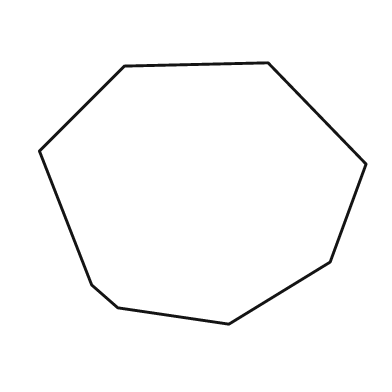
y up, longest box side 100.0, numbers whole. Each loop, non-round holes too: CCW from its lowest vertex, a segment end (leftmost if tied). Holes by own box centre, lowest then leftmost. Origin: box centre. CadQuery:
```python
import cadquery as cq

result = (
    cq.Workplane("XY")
    .moveTo(8.0, -40.0)
    .lineTo(39.0, -21.0)
    .lineTo(50.0, 9.0)
    .lineTo(20.0, 40.0)
    .lineTo(-24.0, 39.0)
    .lineTo(-50.0, 13.0)
    .lineTo(-34.0, -28.0)
    .lineTo(-26.0, -35.0)
    .close()
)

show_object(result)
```